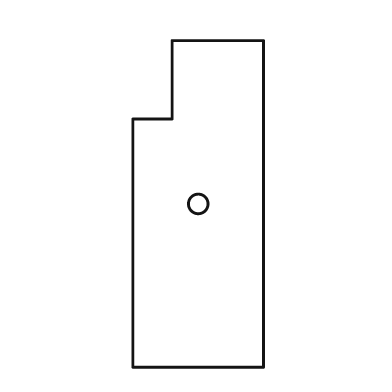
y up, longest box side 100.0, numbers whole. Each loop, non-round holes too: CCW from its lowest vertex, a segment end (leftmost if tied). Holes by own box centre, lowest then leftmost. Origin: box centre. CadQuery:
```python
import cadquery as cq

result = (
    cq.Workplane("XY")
    .moveTo(-20.0, -50.0)
    .lineTo(20.0, -50.0)
    .lineTo(20.0, 50.0)
    .lineTo(-8.0, 50.0)
    .lineTo(-8.0, 26.0)
    .lineTo(-20.0, 26.0)
    .close()
    .moveTo(0.0, 0.0)
    .circle(3.0)
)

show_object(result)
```